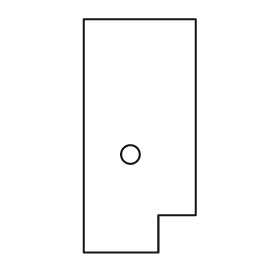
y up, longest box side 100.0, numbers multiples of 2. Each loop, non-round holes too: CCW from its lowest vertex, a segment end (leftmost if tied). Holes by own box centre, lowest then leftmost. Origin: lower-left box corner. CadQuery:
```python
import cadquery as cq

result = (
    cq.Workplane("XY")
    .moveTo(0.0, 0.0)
    .lineTo(32.0, 0.0)
    .lineTo(32.0, 16.0)
    .lineTo(48.0, 16.0)
    .lineTo(48.0, 100.0)
    .lineTo(0.0, 100.0)
    .close()
    .moveTo(20.0, 42.0)
    .circle(4.0)
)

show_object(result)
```